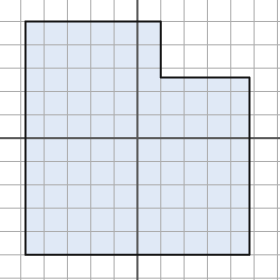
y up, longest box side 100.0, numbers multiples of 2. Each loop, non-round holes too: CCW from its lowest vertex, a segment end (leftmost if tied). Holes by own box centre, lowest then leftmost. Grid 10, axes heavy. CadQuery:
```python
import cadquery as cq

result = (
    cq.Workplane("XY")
    .moveTo(-48.0, -50.0)
    .lineTo(48.0, -50.0)
    .lineTo(48.0, 26.0)
    .lineTo(10.0, 26.0)
    .lineTo(10.0, 50.0)
    .lineTo(-48.0, 50.0)
    .close()
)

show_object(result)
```